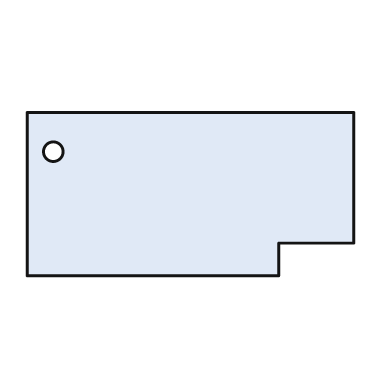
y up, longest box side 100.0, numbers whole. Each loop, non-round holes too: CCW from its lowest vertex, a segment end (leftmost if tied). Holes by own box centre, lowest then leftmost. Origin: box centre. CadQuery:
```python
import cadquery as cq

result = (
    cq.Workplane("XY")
    .moveTo(-50.0, -25.0)
    .lineTo(27.0, -25.0)
    .lineTo(27.0, -15.0)
    .lineTo(50.0, -15.0)
    .lineTo(50.0, 25.0)
    .lineTo(-50.0, 25.0)
    .close()
    .moveTo(-42.0, 13.0)
    .circle(3.0)
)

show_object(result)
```